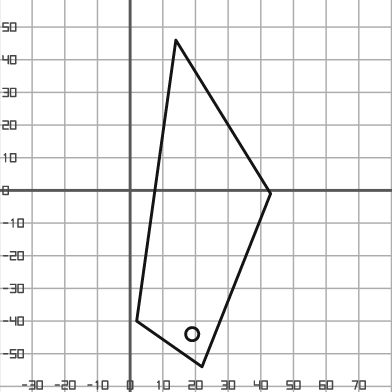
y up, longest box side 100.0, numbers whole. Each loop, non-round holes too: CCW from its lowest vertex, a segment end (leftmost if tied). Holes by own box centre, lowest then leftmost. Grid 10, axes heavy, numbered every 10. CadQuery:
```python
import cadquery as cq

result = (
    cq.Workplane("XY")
    .moveTo(22.0, -54.0)
    .lineTo(43.0, -1.0)
    .lineTo(14.0, 46.0)
    .lineTo(2.0, -40.0)
    .close()
    .moveTo(19.0, -44.0)
    .circle(2.0)
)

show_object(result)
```